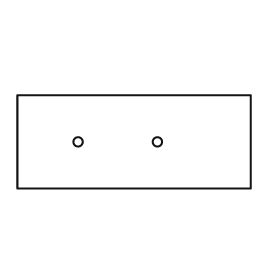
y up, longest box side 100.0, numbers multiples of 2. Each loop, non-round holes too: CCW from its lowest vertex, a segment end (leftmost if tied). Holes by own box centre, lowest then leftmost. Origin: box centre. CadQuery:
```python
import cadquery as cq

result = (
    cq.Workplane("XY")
    .moveTo(-50.0, -20.0)
    .lineTo(50.0, -20.0)
    .lineTo(50.0, 20.0)
    .lineTo(-50.0, 20.0)
    .close()
    .moveTo(-24.0, 0.0)
    .circle(2.0)
    .moveTo(10.0, 0.0)
    .circle(2.0)
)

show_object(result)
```